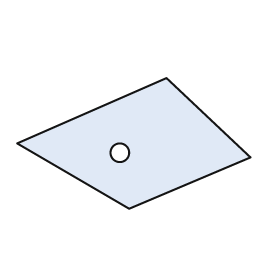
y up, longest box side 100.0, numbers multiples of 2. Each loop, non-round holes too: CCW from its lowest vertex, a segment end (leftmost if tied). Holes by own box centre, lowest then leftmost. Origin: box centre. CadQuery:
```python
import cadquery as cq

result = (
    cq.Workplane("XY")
    .moveTo(-2.0, -28.0)
    .lineTo(50.0, -6.0)
    .lineTo(14.0, 28.0)
    .lineTo(-50.0, 0.0)
    .close()
    .moveTo(-6.0, -4.0)
    .circle(4.0)
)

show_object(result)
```